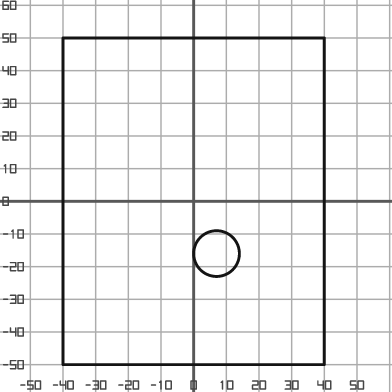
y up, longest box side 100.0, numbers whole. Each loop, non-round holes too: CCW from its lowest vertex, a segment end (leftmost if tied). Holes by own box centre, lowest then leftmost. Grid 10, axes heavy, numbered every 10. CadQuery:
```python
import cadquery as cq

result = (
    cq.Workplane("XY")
    .moveTo(-40.0, -50.0)
    .lineTo(40.0, -50.0)
    .lineTo(40.0, 50.0)
    .lineTo(-40.0, 50.0)
    .close()
    .moveTo(7.0, -16.0)
    .circle(7.0)
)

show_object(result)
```